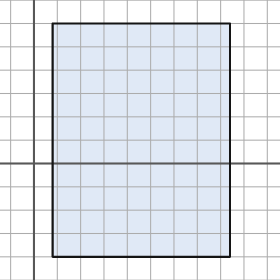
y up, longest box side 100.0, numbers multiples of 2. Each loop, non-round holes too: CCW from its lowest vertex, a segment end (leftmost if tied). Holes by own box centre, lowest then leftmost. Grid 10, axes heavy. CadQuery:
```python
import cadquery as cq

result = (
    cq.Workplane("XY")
    .moveTo(8.0, -40.0)
    .lineTo(84.0, -40.0)
    .lineTo(84.0, 60.0)
    .lineTo(8.0, 60.0)
    .close()
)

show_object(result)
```